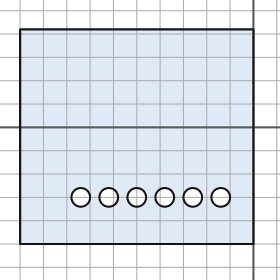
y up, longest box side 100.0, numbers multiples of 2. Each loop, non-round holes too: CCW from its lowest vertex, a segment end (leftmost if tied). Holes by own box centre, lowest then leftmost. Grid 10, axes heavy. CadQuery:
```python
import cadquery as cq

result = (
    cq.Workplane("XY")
    .moveTo(-100.0, -50.0)
    .lineTo(0.0, -50.0)
    .lineTo(0.0, 42.0)
    .lineTo(-100.0, 42.0)
    .close()
    .moveTo(-74.0, -30.0)
    .circle(4.0)
    .moveTo(-62.0, -30.0)
    .circle(4.0)
    .moveTo(-50.0, -30.0)
    .circle(4.0)
    .moveTo(-38.0, -30.0)
    .circle(4.0)
    .moveTo(-26.0, -30.0)
    .circle(4.0)
    .moveTo(-14.0, -30.0)
    .circle(4.0)
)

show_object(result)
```